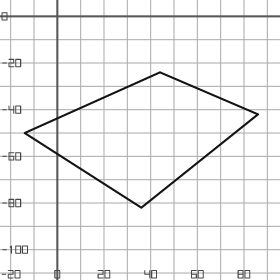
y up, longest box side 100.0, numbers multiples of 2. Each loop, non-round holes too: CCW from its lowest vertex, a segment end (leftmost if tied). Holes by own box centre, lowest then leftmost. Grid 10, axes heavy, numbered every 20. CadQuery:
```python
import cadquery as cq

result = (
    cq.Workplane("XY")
    .moveTo(36.0, -82.0)
    .lineTo(86.0, -42.0)
    .lineTo(44.0, -24.0)
    .lineTo(-14.0, -50.0)
    .close()
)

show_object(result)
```